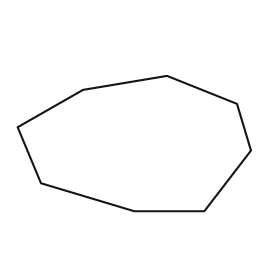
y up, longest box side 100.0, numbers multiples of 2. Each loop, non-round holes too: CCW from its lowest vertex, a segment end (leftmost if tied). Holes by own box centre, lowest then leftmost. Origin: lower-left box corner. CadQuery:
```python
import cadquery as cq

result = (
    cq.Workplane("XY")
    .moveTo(50.0, 0.0)
    .lineTo(80.0, 0.0)
    .lineTo(100.0, 26.0)
    .lineTo(94.0, 46.0)
    .lineTo(64.0, 58.0)
    .lineTo(28.0, 52.0)
    .lineTo(0.0, 36.0)
    .lineTo(10.0, 12.0)
    .close()
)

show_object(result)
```